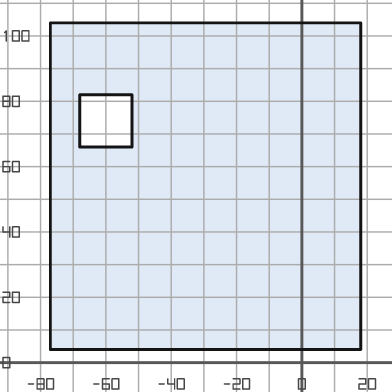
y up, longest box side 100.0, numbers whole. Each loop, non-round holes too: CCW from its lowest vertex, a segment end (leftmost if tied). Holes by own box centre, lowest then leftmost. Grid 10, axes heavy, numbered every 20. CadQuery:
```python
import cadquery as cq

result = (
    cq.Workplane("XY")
    .moveTo(-77.0, 4.0)
    .lineTo(18.0, 4.0)
    .lineTo(18.0, 104.0)
    .lineTo(-77.0, 104.0)
    .close()
    .moveTo(-68.0, 66.0)
    .lineTo(-52.0, 66.0)
    .lineTo(-52.0, 82.0)
    .lineTo(-68.0, 82.0)
    .close()
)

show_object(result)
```